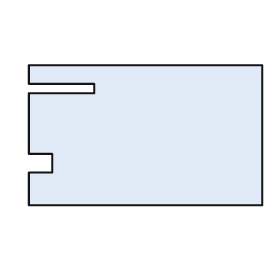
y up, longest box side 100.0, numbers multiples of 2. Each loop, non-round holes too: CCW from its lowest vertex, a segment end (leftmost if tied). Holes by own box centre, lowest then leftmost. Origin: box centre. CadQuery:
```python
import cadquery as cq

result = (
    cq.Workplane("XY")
    .moveTo(-50.0, -30.0)
    .lineTo(50.0, -30.0)
    .lineTo(50.0, 30.0)
    .lineTo(-50.0, 30.0)
    .lineTo(-50.0, 22.0)
    .lineTo(-22.0, 22.0)
    .lineTo(-22.0, 18.0)
    .lineTo(-50.0, 18.0)
    .lineTo(-50.0, -8.0)
    .lineTo(-40.0, -8.0)
    .lineTo(-40.0, -16.0)
    .lineTo(-50.0, -16.0)
    .close()
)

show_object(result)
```